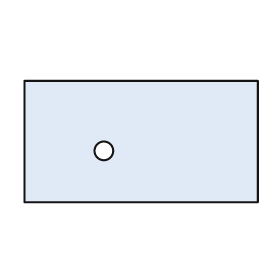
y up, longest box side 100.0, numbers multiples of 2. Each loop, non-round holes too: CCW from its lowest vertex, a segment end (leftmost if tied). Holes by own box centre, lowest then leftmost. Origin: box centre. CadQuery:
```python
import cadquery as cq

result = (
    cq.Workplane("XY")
    .moveTo(-50.0, -26.0)
    .lineTo(50.0, -26.0)
    .lineTo(50.0, 26.0)
    .lineTo(-50.0, 26.0)
    .close()
    .moveTo(-16.0, -4.0)
    .circle(4.0)
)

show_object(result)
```